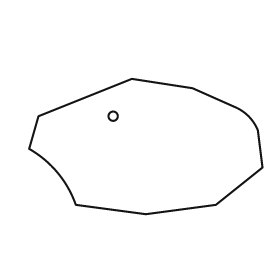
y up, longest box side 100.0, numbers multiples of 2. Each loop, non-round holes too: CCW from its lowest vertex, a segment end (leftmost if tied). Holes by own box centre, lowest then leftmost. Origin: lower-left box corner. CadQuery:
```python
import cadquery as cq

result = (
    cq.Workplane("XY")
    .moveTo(50.0, 0.0)
    .lineTo(80.0, 4.0)
    .lineTo(100.0, 20.0)
    .lineTo(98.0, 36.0)
    .threePointArc((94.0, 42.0), (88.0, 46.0))
    .lineTo(70.0, 54.0)
    .lineTo(44.0, 58.0)
    .lineTo(4.0, 42.0)
    .lineTo(0.0, 28.0)
    .threePointArc((12.0, 18.0), (20.0, 4.0))
    .close()
    .moveTo(36.0, 42.0)
    .circle(2.0)
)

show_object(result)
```